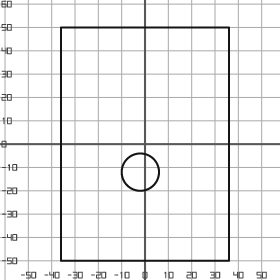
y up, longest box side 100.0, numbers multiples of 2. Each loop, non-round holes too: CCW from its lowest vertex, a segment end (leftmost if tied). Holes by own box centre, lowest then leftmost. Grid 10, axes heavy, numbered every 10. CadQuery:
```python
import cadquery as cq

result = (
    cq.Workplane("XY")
    .moveTo(-36.0, -50.0)
    .lineTo(36.0, -50.0)
    .lineTo(36.0, 50.0)
    .lineTo(-36.0, 50.0)
    .close()
    .moveTo(-2.0, -12.0)
    .circle(8.0)
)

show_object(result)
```